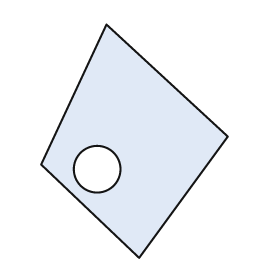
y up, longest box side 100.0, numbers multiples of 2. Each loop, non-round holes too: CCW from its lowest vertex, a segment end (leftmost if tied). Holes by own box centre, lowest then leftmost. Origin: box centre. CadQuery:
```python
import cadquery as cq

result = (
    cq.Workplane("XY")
    .moveTo(2.0, -50.0)
    .lineTo(40.0, 2.0)
    .lineTo(-12.0, 50.0)
    .lineTo(-40.0, -10.0)
    .close()
    .moveTo(-16.0, -12.0)
    .circle(10.0)
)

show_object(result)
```